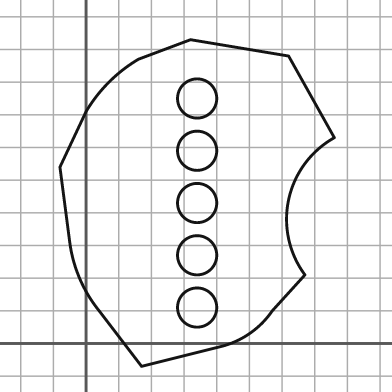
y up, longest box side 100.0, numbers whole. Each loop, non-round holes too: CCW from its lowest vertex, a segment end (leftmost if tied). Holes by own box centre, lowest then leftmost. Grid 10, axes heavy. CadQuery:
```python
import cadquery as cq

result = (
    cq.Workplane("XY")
    .moveTo(17.0, -7.0)
    .lineTo(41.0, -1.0)
    .threePointArc((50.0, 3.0), (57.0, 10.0))
    .lineTo(67.0, 21.0)
    .threePointArc((62.0, 44.0), (76.0, 63.0))
    .lineTo(62.0, 88.0)
    .lineTo(32.0, 93.0)
    .lineTo(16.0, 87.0)
    .threePointArc((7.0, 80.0), (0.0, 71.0))
    .lineTo(-8.0, 54.0)
    .lineTo(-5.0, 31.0)
    .threePointArc((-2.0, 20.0), (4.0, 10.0))
    .close()
    .moveTo(34.0, 11.0)
    .circle(6.0)
    .moveTo(34.0, 27.0)
    .circle(6.0)
    .moveTo(34.0, 43.0)
    .circle(6.0)
    .moveTo(34.0, 59.0)
    .circle(6.0)
    .moveTo(34.0, 75.0)
    .circle(6.0)
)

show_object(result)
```